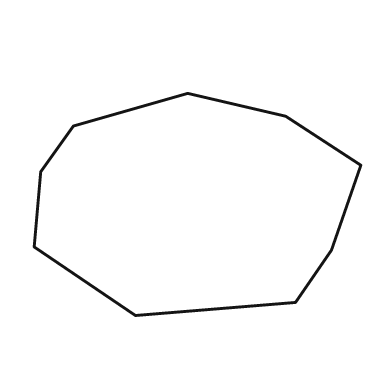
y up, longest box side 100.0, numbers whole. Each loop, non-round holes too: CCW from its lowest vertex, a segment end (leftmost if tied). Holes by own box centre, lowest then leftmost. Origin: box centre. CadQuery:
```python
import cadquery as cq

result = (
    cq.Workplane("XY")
    .moveTo(-19.0, -34.0)
    .lineTo(30.0, -30.0)
    .lineTo(41.0, -14.0)
    .lineTo(50.0, 12.0)
    .lineTo(27.0, 27.0)
    .lineTo(-3.0, 34.0)
    .lineTo(-38.0, 24.0)
    .lineTo(-48.0, 10.0)
    .lineTo(-50.0, -13.0)
    .close()
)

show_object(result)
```